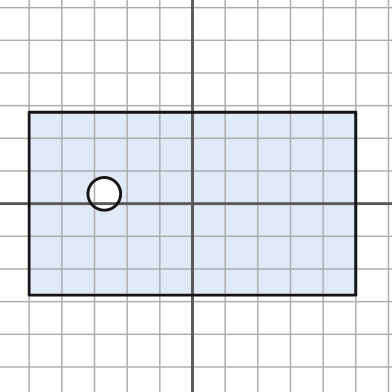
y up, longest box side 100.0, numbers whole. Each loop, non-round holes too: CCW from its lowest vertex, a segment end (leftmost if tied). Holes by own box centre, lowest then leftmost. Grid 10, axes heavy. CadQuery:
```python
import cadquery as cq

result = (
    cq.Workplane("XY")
    .moveTo(-50.0, -28.0)
    .lineTo(50.0, -28.0)
    .lineTo(50.0, 28.0)
    .lineTo(-50.0, 28.0)
    .close()
    .moveTo(-27.0, 3.0)
    .circle(5.0)
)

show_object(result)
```